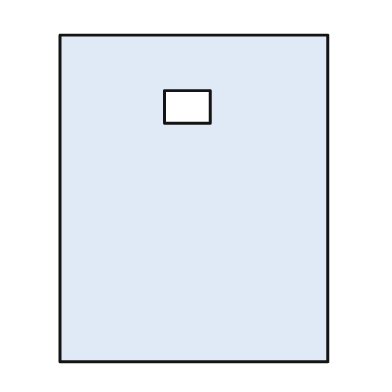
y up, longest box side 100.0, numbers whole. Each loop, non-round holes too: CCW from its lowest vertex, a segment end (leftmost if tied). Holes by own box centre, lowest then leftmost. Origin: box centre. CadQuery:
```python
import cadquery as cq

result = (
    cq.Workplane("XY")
    .moveTo(-41.0, -50.0)
    .lineTo(41.0, -50.0)
    .lineTo(41.0, 50.0)
    .lineTo(-41.0, 50.0)
    .close()
    .moveTo(-9.0, 23.0)
    .lineTo(5.0, 23.0)
    .lineTo(5.0, 33.0)
    .lineTo(-9.0, 33.0)
    .close()
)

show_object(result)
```